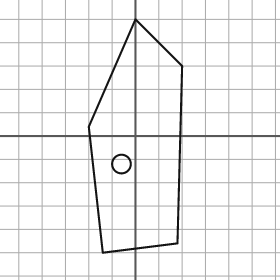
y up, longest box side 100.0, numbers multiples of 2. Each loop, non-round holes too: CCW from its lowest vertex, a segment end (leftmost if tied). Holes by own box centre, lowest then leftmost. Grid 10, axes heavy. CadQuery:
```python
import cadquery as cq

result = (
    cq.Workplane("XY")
    .moveTo(-14.0, -50.0)
    .lineTo(18.0, -46.0)
    .lineTo(20.0, 30.0)
    .lineTo(0.0, 50.0)
    .lineTo(-20.0, 4.0)
    .close()
    .moveTo(-6.0, -12.0)
    .circle(4.0)
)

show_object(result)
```